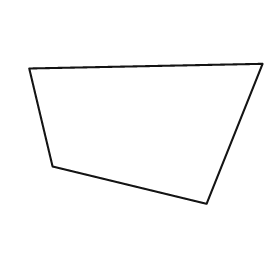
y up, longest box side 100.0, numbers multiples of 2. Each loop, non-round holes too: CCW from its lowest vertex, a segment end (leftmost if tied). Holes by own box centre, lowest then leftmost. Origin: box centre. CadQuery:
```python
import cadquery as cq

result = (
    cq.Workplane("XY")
    .moveTo(26.0, -30.0)
    .lineTo(50.0, 30.0)
    .lineTo(-50.0, 28.0)
    .lineTo(-40.0, -14.0)
    .close()
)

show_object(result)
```